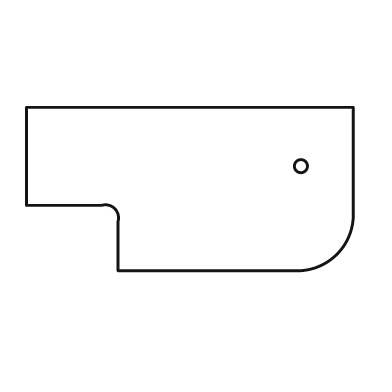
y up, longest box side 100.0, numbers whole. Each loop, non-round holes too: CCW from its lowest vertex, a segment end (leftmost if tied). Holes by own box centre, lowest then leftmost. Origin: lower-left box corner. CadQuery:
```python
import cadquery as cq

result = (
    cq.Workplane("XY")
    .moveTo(28.0, 0.0)
    .lineTo(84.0, 0.0)
    .threePointArc((95.0, 5.0), (100.0, 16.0))
    .lineTo(100.0, 50.0)
    .lineTo(0.0, 50.0)
    .lineTo(0.0, 20.0)
    .lineTo(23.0, 20.0)
    .threePointArc((27.0, 19.0), (28.0, 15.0))
    .close()
    .moveTo(84.0, 32.0)
    .circle(2.0)
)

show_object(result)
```